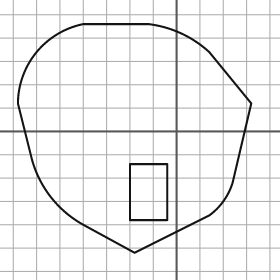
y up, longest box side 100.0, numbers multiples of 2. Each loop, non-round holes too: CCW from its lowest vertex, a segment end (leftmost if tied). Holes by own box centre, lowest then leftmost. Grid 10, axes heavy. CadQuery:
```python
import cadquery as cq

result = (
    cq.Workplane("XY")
    .moveTo(-18.0, -52.0)
    .lineTo(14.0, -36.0)
    .threePointArc((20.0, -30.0), (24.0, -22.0))
    .lineTo(32.0, 12.0)
    .lineTo(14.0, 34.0)
    .threePointArc((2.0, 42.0), (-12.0, 46.0))
    .lineTo(-40.0, 46.0)
    .threePointArc((-60.0, 34.0), (-68.0, 12.0))
    .lineTo(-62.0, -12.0)
    .threePointArc((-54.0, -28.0), (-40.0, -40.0))
    .close()
    .moveTo(-20.0, -38.0)
    .lineTo(-4.0, -38.0)
    .lineTo(-4.0, -14.0)
    .lineTo(-20.0, -14.0)
    .close()
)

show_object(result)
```